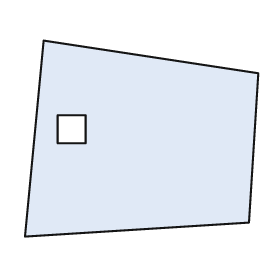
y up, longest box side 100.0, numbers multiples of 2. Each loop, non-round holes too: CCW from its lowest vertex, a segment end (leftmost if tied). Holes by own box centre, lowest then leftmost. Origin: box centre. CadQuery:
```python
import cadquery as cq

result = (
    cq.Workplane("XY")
    .moveTo(-50.0, -42.0)
    .lineTo(46.0, -36.0)
    .lineTo(50.0, 28.0)
    .lineTo(-42.0, 42.0)
    .close()
    .moveTo(-36.0, -2.0)
    .lineTo(-24.0, -2.0)
    .lineTo(-24.0, 10.0)
    .lineTo(-36.0, 10.0)
    .close()
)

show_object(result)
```